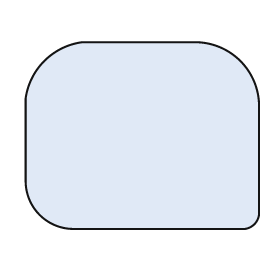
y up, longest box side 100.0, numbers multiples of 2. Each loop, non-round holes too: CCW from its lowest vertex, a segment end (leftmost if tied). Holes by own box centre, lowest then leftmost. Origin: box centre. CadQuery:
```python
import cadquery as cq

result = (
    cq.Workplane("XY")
    .moveTo(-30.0, -40.0)
    .lineTo(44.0, -40.0)
    .threePointArc((48.0, -38.0), (50.0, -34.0))
    .lineTo(50.0, 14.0)
    .threePointArc((42.0, 32.0), (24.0, 40.0))
    .lineTo(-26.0, 40.0)
    .threePointArc((-42.0, 32.0), (-50.0, 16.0))
    .lineTo(-50.0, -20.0)
    .threePointArc((-44.0, -34.0), (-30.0, -40.0))
    .close()
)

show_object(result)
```